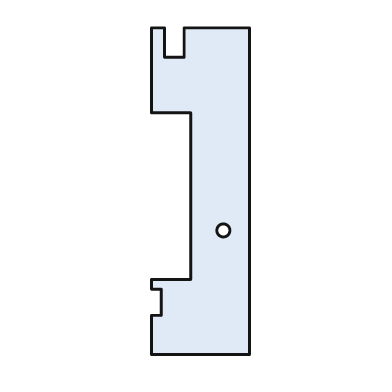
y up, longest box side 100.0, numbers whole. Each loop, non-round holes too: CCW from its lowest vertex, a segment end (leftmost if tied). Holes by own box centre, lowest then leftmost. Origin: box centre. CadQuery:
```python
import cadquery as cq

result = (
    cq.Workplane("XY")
    .moveTo(-15.0, -50.0)
    .lineTo(15.0, -50.0)
    .lineTo(15.0, 50.0)
    .lineTo(-5.0, 50.0)
    .lineTo(-5.0, 41.0)
    .lineTo(-11.0, 41.0)
    .lineTo(-11.0, 50.0)
    .lineTo(-15.0, 50.0)
    .lineTo(-15.0, 24.0)
    .lineTo(-3.0, 24.0)
    .lineTo(-3.0, -27.0)
    .lineTo(-15.0, -27.0)
    .lineTo(-15.0, -30.0)
    .lineTo(-12.0, -30.0)
    .lineTo(-12.0, -38.0)
    .lineTo(-15.0, -38.0)
    .close()
    .moveTo(7.0, -12.0)
    .circle(2.0)
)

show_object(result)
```